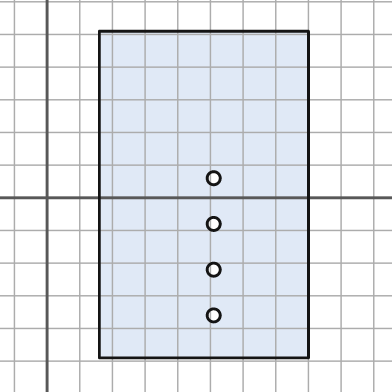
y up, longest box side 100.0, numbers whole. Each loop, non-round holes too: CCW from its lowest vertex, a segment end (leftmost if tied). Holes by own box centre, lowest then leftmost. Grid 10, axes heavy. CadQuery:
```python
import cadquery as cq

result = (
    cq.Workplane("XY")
    .moveTo(16.0, -49.0)
    .lineTo(80.0, -49.0)
    .lineTo(80.0, 51.0)
    .lineTo(16.0, 51.0)
    .close()
    .moveTo(51.0, -36.0)
    .circle(2.0)
    .moveTo(51.0, -22.0)
    .circle(2.0)
    .moveTo(51.0, -8.0)
    .circle(2.0)
    .moveTo(51.0, 6.0)
    .circle(2.0)
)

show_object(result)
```